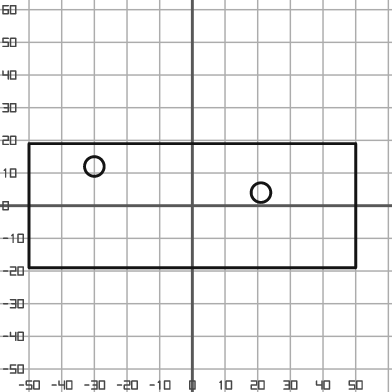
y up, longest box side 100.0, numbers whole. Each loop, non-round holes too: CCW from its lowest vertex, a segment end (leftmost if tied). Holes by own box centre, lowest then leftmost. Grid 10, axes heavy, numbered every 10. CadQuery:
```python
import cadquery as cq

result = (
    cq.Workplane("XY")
    .moveTo(-50.0, -19.0)
    .lineTo(50.0, -19.0)
    .lineTo(50.0, 19.0)
    .lineTo(-50.0, 19.0)
    .close()
    .moveTo(21.0, 4.0)
    .circle(3.0)
    .moveTo(-30.0, 12.0)
    .circle(3.0)
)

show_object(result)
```